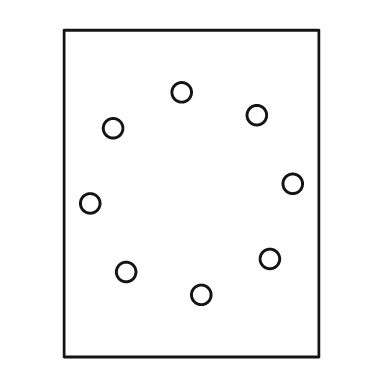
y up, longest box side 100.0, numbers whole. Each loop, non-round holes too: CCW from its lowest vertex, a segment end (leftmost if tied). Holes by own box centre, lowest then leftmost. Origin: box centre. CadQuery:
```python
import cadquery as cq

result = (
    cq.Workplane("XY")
    .moveTo(-39.0, -50.0)
    .lineTo(39.0, -50.0)
    .lineTo(39.0, 50.0)
    .lineTo(-39.0, 50.0)
    .close()
    .moveTo(3.0, -31.0)
    .circle(3.0)
    .moveTo(-20.0, -24.0)
    .circle(3.0)
    .moveTo(24.0, -20.0)
    .circle(3.0)
    .moveTo(-31.0, -3.0)
    .circle(3.0)
    .moveTo(31.0, 3.0)
    .circle(3.0)
    .moveTo(-24.0, 20.0)
    .circle(3.0)
    .moveTo(20.0, 24.0)
    .circle(3.0)
    .moveTo(-3.0, 31.0)
    .circle(3.0)
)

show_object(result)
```